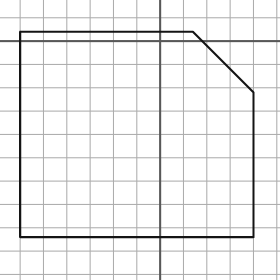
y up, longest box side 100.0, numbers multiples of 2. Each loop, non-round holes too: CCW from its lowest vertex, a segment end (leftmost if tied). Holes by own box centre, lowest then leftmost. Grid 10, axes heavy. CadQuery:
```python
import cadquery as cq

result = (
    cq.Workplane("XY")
    .moveTo(-60.0, -84.0)
    .lineTo(40.0, -84.0)
    .lineTo(40.0, -22.0)
    .lineTo(14.0, 4.0)
    .lineTo(-60.0, 4.0)
    .close()
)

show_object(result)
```